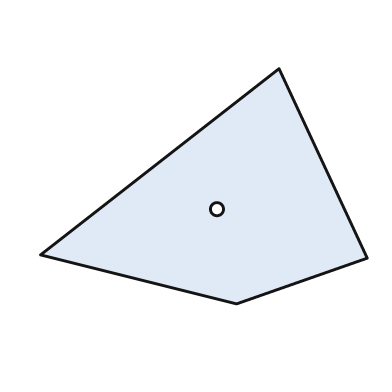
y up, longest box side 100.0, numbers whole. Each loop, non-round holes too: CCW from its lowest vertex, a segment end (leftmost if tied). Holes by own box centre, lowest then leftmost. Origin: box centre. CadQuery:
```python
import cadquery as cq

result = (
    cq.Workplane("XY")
    .moveTo(10.0, -36.0)
    .lineTo(50.0, -22.0)
    .lineTo(23.0, 36.0)
    .lineTo(-50.0, -21.0)
    .close()
    .moveTo(4.0, -7.0)
    .circle(2.0)
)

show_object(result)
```